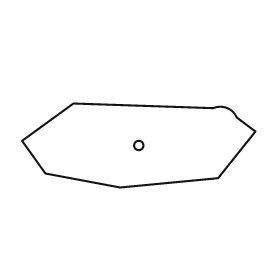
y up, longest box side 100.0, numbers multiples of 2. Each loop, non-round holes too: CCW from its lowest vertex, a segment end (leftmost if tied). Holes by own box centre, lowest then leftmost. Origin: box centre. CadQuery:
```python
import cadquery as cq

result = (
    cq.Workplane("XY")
    .moveTo(-8.0, -18.0)
    .lineTo(34.0, -14.0)
    .lineTo(50.0, 6.0)
    .lineTo(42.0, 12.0)
    .threePointArc((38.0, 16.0), (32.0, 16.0))
    .lineTo(-28.0, 18.0)
    .lineTo(-50.0, 2.0)
    .lineTo(-40.0, -12.0)
    .close()
    .moveTo(0.0, 0.0)
    .circle(2.0)
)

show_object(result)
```